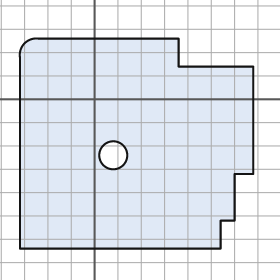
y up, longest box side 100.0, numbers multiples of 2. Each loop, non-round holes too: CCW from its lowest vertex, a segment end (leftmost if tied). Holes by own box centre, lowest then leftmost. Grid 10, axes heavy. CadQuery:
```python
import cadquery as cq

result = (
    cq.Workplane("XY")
    .moveTo(-32.0, -64.0)
    .lineTo(54.0, -64.0)
    .lineTo(54.0, -52.0)
    .lineTo(60.0, -52.0)
    .lineTo(60.0, -32.0)
    .lineTo(68.0, -32.0)
    .lineTo(68.0, 14.0)
    .lineTo(36.0, 14.0)
    .lineTo(36.0, 26.0)
    .lineTo(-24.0, 26.0)
    .threePointArc((-30.0, 24.0), (-32.0, 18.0))
    .close()
    .moveTo(8.0, -24.0)
    .circle(6.0)
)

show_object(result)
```